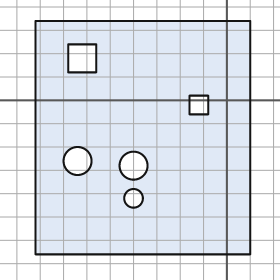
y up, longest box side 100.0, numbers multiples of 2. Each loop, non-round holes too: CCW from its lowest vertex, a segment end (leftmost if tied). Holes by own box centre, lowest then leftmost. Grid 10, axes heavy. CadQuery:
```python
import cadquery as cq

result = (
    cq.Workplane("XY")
    .moveTo(-82.0, -66.0)
    .lineTo(10.0, -66.0)
    .lineTo(10.0, 34.0)
    .lineTo(-82.0, 34.0)
    .close()
    .moveTo(-40.0, -42.0)
    .circle(4.0)
    .moveTo(-40.0, -28.0)
    .circle(6.0)
    .moveTo(-64.0, -26.0)
    .circle(6.0)
    .moveTo(-16.0, -6.0)
    .lineTo(-8.0, -6.0)
    .lineTo(-8.0, 2.0)
    .lineTo(-16.0, 2.0)
    .close()
    .moveTo(-68.0, 12.0)
    .lineTo(-56.0, 12.0)
    .lineTo(-56.0, 24.0)
    .lineTo(-68.0, 24.0)
    .close()
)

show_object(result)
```